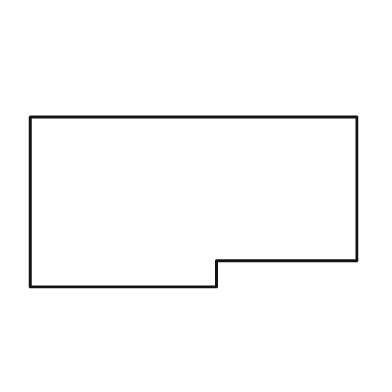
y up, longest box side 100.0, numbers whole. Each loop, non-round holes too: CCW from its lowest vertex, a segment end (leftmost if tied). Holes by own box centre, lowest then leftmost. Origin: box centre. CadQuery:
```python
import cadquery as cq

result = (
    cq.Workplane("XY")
    .moveTo(-50.0, -26.0)
    .lineTo(7.0, -26.0)
    .lineTo(7.0, -18.0)
    .lineTo(50.0, -18.0)
    .lineTo(50.0, 26.0)
    .lineTo(-50.0, 26.0)
    .close()
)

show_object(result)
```